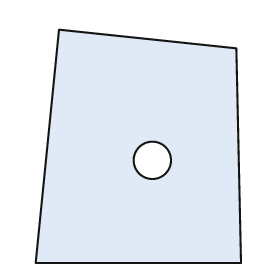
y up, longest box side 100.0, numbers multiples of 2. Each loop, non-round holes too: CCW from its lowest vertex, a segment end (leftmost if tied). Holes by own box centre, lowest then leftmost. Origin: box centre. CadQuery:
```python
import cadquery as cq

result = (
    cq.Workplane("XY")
    .moveTo(-44.0, -50.0)
    .lineTo(44.0, -50.0)
    .lineTo(42.0, 42.0)
    .lineTo(-34.0, 50.0)
    .close()
    .moveTo(6.0, -6.0)
    .circle(8.0)
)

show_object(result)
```